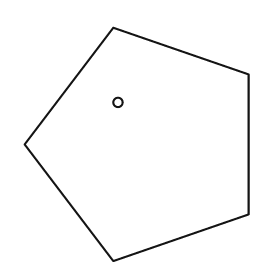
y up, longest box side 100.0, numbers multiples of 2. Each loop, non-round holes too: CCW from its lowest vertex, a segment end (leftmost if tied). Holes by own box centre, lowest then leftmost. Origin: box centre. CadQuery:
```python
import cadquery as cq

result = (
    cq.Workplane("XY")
    .moveTo(-10.0, -50.0)
    .lineTo(48.0, -30.0)
    .lineTo(48.0, 30.0)
    .lineTo(-10.0, 50.0)
    .lineTo(-48.0, 0.0)
    .close()
    .moveTo(-8.0, 18.0)
    .circle(2.0)
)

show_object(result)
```